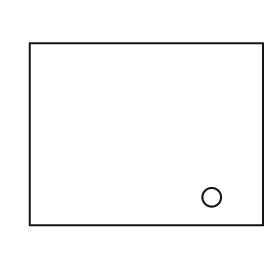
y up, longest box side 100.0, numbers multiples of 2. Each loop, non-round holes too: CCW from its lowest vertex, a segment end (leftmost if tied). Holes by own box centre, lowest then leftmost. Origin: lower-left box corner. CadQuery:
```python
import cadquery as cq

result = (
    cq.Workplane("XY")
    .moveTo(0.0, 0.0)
    .lineTo(100.0, 0.0)
    .lineTo(100.0, 78.0)
    .lineTo(0.0, 78.0)
    .close()
    .moveTo(78.0, 12.0)
    .circle(4.0)
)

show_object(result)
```